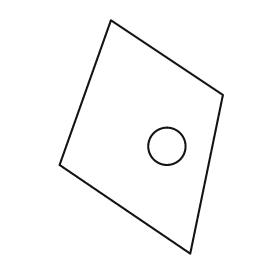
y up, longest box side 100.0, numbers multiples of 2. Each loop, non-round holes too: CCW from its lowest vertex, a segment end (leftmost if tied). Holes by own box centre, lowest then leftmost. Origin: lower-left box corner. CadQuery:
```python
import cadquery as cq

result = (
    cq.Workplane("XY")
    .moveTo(56.0, 0.0)
    .lineTo(70.0, 68.0)
    .lineTo(22.0, 100.0)
    .lineTo(0.0, 38.0)
    .close()
    .moveTo(46.0, 46.0)
    .circle(8.0)
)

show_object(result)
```